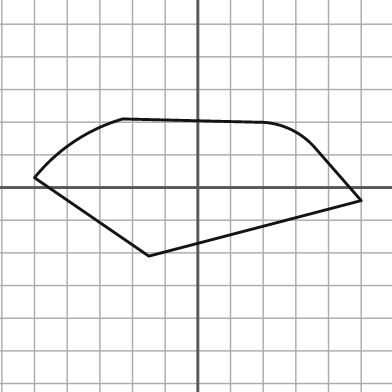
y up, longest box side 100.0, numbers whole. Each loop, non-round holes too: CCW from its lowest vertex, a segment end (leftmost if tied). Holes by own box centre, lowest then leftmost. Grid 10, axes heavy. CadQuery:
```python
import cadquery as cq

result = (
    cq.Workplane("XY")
    .moveTo(-15.0, -21.0)
    .lineTo(50.0, -4.0)
    .lineTo(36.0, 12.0)
    .threePointArc((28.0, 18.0), (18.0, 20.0))
    .lineTo(-23.0, 21.0)
    .threePointArc((-38.0, 14.0), (-50.0, 3.0))
    .close()
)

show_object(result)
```